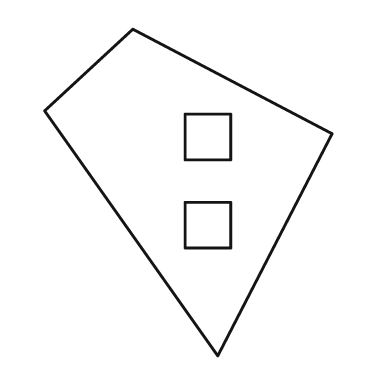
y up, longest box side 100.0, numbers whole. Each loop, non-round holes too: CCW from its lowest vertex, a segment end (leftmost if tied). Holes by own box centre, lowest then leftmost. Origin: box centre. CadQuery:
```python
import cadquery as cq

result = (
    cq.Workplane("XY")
    .moveTo(9.0, -50.0)
    .lineTo(44.0, 18.0)
    .lineTo(-17.0, 50.0)
    .lineTo(-44.0, 25.0)
    .close()
    .moveTo(-1.0, -17.0)
    .lineTo(13.0, -17.0)
    .lineTo(13.0, -3.0)
    .lineTo(-1.0, -3.0)
    .close()
    .moveTo(-1.0, 10.0)
    .lineTo(13.0, 10.0)
    .lineTo(13.0, 24.0)
    .lineTo(-1.0, 24.0)
    .close()
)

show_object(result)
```